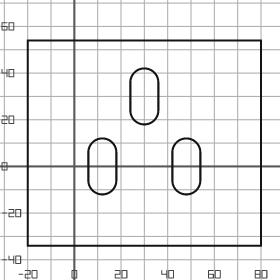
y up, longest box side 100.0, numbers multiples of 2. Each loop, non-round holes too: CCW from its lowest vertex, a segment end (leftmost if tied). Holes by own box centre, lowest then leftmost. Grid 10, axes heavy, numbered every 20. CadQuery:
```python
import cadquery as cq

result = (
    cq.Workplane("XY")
    .moveTo(-20.0, -34.0)
    .lineTo(80.0, -34.0)
    .lineTo(80.0, 54.0)
    .lineTo(-20.0, 54.0)
    .close()
    .moveTo(6.0, -6.0)
    .threePointArc((12.0, -12.0), (18.0, -6.0))
    .lineTo(18.0, 6.0)
    .threePointArc((12.0, 12.0), (6.0, 6.0))
    .close()
    .moveTo(42.0, -6.0)
    .threePointArc((48.0, -12.0), (54.0, -6.0))
    .lineTo(54.0, 6.0)
    .threePointArc((48.0, 12.0), (42.0, 6.0))
    .close()
    .moveTo(24.0, 24.0)
    .threePointArc((30.0, 18.0), (36.0, 24.0))
    .lineTo(36.0, 36.0)
    .threePointArc((30.0, 42.0), (24.0, 36.0))
    .close()
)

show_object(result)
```